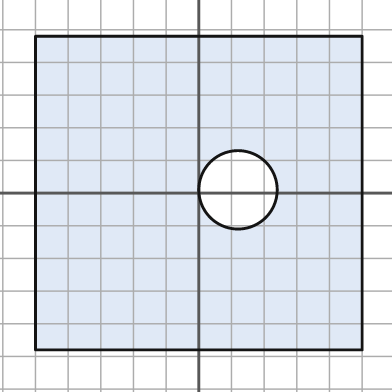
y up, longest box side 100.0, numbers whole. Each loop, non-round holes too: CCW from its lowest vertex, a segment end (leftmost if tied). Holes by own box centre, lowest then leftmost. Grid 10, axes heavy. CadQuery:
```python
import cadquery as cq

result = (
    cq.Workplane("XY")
    .moveTo(-50.0, -48.0)
    .lineTo(50.0, -48.0)
    .lineTo(50.0, 48.0)
    .lineTo(-50.0, 48.0)
    .close()
    .moveTo(12.0, 1.0)
    .circle(12.0)
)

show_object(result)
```